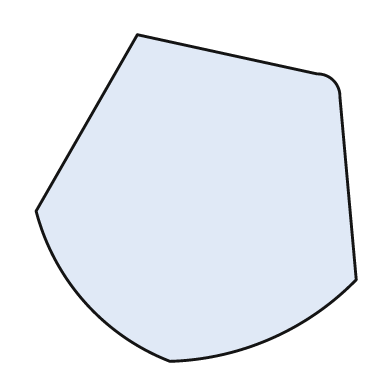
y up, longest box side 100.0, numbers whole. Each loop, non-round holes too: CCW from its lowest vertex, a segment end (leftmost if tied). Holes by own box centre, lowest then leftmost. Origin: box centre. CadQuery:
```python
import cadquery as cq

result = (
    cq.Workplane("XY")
    .moveTo(-8.0, -50.0)
    .threePointArc((23.0, -43.0), (49.0, -25.0))
    .lineTo(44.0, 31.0)
    .threePointArc((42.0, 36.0), (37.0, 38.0))
    .lineTo(-18.0, 50.0)
    .lineTo(-49.0, -4.0)
    .threePointArc((-34.0, -32.0), (-8.0, -50.0))
    .close()
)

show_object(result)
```